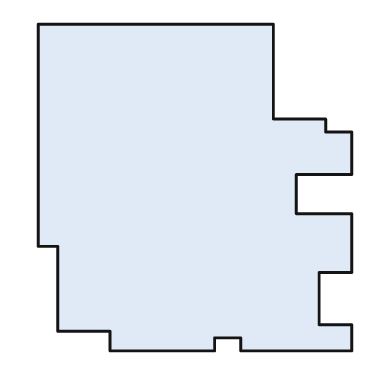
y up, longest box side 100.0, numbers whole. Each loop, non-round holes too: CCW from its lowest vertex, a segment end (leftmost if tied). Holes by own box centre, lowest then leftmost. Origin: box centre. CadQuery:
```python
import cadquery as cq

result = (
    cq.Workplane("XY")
    .moveTo(-26.0, -50.0)
    .lineTo(6.0, -50.0)
    .lineTo(6.0, -46.0)
    .lineTo(14.0, -46.0)
    .lineTo(14.0, -50.0)
    .lineTo(48.0, -50.0)
    .lineTo(48.0, -42.0)
    .lineTo(38.0, -42.0)
    .lineTo(38.0, -26.0)
    .lineTo(48.0, -26.0)
    .lineTo(48.0, -8.0)
    .lineTo(31.0, -8.0)
    .lineTo(31.0, 4.0)
    .lineTo(48.0, 4.0)
    .lineTo(48.0, 17.0)
    .lineTo(40.0, 17.0)
    .lineTo(40.0, 21.0)
    .lineTo(24.0, 21.0)
    .lineTo(24.0, 50.0)
    .lineTo(-48.0, 50.0)
    .lineTo(-48.0, -18.0)
    .lineTo(-42.0, -18.0)
    .lineTo(-42.0, -44.0)
    .lineTo(-26.0, -44.0)
    .close()
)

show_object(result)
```